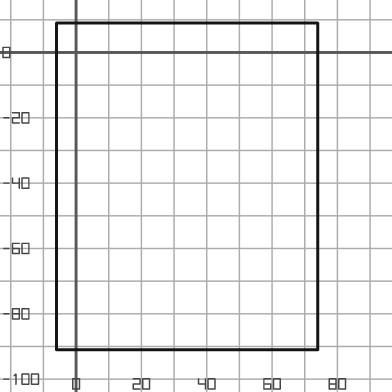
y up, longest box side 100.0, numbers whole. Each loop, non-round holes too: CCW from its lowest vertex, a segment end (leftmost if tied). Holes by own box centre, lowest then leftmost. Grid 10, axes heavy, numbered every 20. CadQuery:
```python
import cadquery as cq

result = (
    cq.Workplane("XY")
    .moveTo(-6.0, -91.0)
    .lineTo(74.0, -91.0)
    .lineTo(74.0, 9.0)
    .lineTo(-6.0, 9.0)
    .close()
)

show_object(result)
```